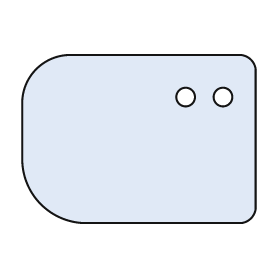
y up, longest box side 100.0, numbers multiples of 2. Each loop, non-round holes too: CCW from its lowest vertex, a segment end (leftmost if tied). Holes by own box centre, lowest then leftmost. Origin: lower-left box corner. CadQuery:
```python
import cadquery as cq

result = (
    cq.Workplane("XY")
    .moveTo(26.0, 0.0)
    .lineTo(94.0, 0.0)
    .threePointArc((98.0, 2.0), (100.0, 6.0))
    .lineTo(100.0, 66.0)
    .threePointArc((98.0, 70.0), (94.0, 72.0))
    .lineTo(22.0, 72.0)
    .threePointArc((6.0, 66.0), (0.0, 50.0))
    .lineTo(0.0, 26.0)
    .threePointArc((8.0, 8.0), (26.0, 0.0))
    .close()
    .moveTo(70.0, 54.0)
    .circle(4.0)
    .moveTo(86.0, 54.0)
    .circle(4.0)
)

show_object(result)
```